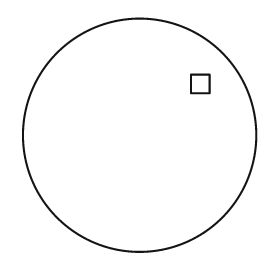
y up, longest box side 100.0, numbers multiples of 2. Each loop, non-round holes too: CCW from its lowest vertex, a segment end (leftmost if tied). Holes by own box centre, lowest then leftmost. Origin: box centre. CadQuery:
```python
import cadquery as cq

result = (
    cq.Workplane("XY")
    .moveTo(0.0, 0.0)
    .circle(50.0)
    .moveTo(22.0, 18.0)
    .lineTo(30.0, 18.0)
    .lineTo(30.0, 26.0)
    .lineTo(22.0, 26.0)
    .close()
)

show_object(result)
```